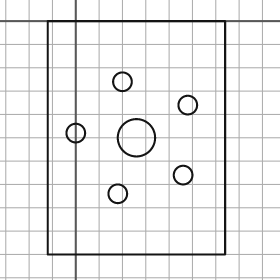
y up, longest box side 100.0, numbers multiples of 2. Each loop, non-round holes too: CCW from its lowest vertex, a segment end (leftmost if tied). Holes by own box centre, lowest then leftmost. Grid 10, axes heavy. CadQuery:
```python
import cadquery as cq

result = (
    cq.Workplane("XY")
    .moveTo(-12.0, -100.0)
    .lineTo(64.0, -100.0)
    .lineTo(64.0, 0.0)
    .lineTo(-12.0, 0.0)
    .close()
    .moveTo(18.0, -74.0)
    .circle(4.0)
    .moveTo(46.0, -66.0)
    .circle(4.0)
    .moveTo(26.0, -50.0)
    .circle(8.0)
    .moveTo(0.0, -48.0)
    .circle(4.0)
    .moveTo(48.0, -36.0)
    .circle(4.0)
    .moveTo(20.0, -26.0)
    .circle(4.0)
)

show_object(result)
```